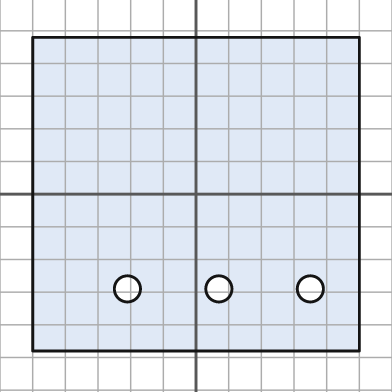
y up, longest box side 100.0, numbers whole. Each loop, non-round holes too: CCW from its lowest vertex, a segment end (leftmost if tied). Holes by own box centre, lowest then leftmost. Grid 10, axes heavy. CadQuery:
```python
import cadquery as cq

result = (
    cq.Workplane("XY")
    .moveTo(-50.0, -48.0)
    .lineTo(50.0, -48.0)
    .lineTo(50.0, 48.0)
    .lineTo(-50.0, 48.0)
    .close()
    .moveTo(-21.0, -29.0)
    .circle(4.0)
    .moveTo(7.0, -29.0)
    .circle(4.0)
    .moveTo(35.0, -29.0)
    .circle(4.0)
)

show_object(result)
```